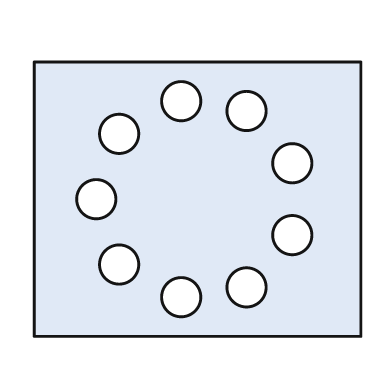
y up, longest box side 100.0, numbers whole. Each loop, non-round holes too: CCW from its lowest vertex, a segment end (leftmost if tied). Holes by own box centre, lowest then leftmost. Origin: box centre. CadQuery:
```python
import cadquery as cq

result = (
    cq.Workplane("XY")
    .moveTo(-50.0, -42.0)
    .lineTo(50.0, -42.0)
    .lineTo(50.0, 42.0)
    .lineTo(-50.0, 42.0)
    .close()
    .moveTo(-5.0, -30.0)
    .circle(6.0)
    .moveTo(15.0, -27.0)
    .circle(6.0)
    .moveTo(-24.0, -20.0)
    .circle(6.0)
    .moveTo(29.0, -11.0)
    .circle(6.0)
    .moveTo(-31.0, 0.0)
    .circle(6.0)
    .moveTo(29.0, 11.0)
    .circle(6.0)
    .moveTo(-24.0, 20.0)
    .circle(6.0)
    .moveTo(15.0, 27.0)
    .circle(6.0)
    .moveTo(-5.0, 30.0)
    .circle(6.0)
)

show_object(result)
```